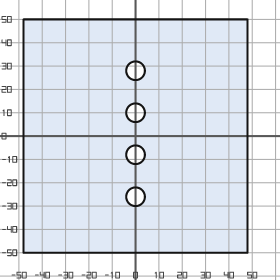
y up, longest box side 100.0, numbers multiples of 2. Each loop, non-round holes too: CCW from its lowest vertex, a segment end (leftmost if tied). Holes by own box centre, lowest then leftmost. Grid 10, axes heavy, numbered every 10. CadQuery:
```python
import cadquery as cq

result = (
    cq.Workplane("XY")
    .moveTo(-48.0, -50.0)
    .lineTo(48.0, -50.0)
    .lineTo(48.0, 50.0)
    .lineTo(-48.0, 50.0)
    .close()
    .moveTo(0.0, -26.0)
    .circle(4.0)
    .moveTo(0.0, -8.0)
    .circle(4.0)
    .moveTo(0.0, 10.0)
    .circle(4.0)
    .moveTo(0.0, 28.0)
    .circle(4.0)
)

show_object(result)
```